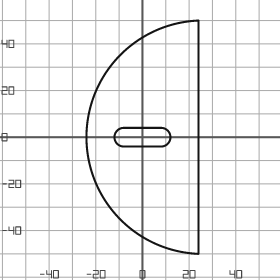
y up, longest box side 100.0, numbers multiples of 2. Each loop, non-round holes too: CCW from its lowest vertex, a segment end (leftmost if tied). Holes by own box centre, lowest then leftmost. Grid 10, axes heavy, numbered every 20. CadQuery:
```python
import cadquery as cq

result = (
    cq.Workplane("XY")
    .moveTo(24.0, -50.0)
    .lineTo(24.0, 50.0)
    .threePointArc((-24.0, 0.0), (24.0, -50.0))
    .close()
    .moveTo(-8.0, -4.0)
    .lineTo(8.0, -4.0)
    .threePointArc((12.0, 0.0), (8.0, 4.0))
    .lineTo(-8.0, 4.0)
    .threePointArc((-12.0, 0.0), (-8.0, -4.0))
    .close()
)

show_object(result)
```